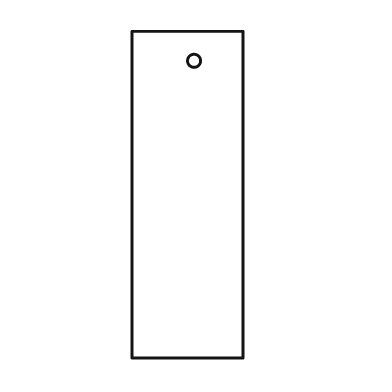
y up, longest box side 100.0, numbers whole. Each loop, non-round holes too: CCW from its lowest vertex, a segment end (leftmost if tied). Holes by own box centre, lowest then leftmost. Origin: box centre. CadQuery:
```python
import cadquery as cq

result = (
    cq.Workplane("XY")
    .moveTo(-17.0, -50.0)
    .lineTo(17.0, -50.0)
    .lineTo(17.0, 50.0)
    .lineTo(-17.0, 50.0)
    .close()
    .moveTo(2.0, 41.0)
    .circle(2.0)
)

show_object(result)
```